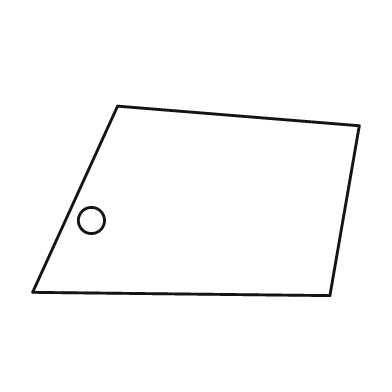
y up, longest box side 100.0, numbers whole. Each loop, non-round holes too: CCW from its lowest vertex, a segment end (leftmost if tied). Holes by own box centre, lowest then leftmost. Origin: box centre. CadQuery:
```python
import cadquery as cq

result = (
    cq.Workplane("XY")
    .moveTo(41.0, -29.0)
    .lineTo(50.0, 23.0)
    .lineTo(-24.0, 29.0)
    .lineTo(-50.0, -28.0)
    .close()
    .moveTo(-32.0, -6.0)
    .circle(4.0)
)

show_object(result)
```